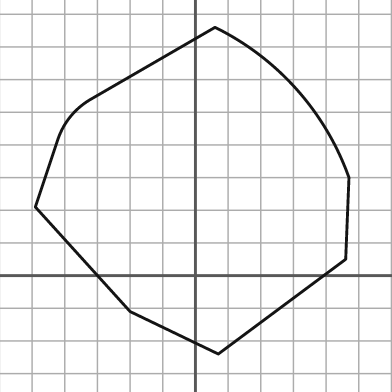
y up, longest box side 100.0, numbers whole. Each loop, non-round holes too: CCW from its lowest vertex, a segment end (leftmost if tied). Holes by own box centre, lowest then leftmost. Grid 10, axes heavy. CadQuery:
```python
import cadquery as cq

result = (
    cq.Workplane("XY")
    .moveTo(7.0, -24.0)
    .lineTo(46.0, 5.0)
    .lineTo(47.0, 30.0)
    .threePointArc((31.0, 57.0), (6.0, 76.0))
    .lineTo(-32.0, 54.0)
    .threePointArc((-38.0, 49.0), (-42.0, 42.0))
    .lineTo(-49.0, 21.0)
    .lineTo(-20.0, -11.0)
    .close()
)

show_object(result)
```